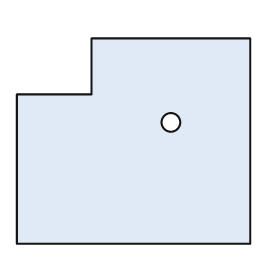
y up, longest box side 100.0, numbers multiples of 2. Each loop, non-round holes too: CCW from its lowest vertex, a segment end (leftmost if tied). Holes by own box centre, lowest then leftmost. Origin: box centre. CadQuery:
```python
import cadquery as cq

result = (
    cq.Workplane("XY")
    .moveTo(-50.0, -44.0)
    .lineTo(50.0, -44.0)
    .lineTo(50.0, 44.0)
    .lineTo(-18.0, 44.0)
    .lineTo(-18.0, 20.0)
    .lineTo(-50.0, 20.0)
    .close()
    .moveTo(16.0, 8.0)
    .circle(4.0)
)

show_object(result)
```